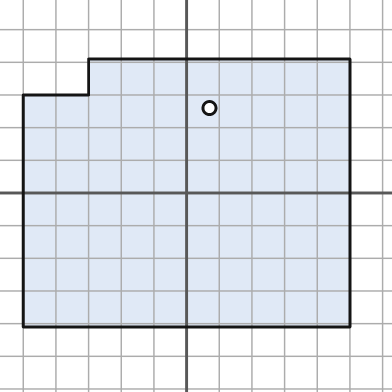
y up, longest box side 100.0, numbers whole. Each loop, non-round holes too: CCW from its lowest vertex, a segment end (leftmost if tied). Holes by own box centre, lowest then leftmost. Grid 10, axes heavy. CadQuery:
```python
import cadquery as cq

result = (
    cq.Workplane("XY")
    .moveTo(-50.0, -41.0)
    .lineTo(50.0, -41.0)
    .lineTo(50.0, 41.0)
    .lineTo(-30.0, 41.0)
    .lineTo(-30.0, 30.0)
    .lineTo(-50.0, 30.0)
    .close()
    .moveTo(7.0, 26.0)
    .circle(2.0)
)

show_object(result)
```